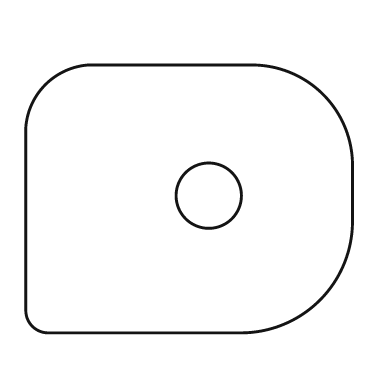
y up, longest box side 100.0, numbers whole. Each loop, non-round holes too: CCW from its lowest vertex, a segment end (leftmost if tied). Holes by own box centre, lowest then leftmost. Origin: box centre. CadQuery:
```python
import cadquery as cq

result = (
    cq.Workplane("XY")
    .moveTo(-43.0, -41.0)
    .lineTo(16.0, -41.0)
    .threePointArc((40.0, -31.0), (50.0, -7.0))
    .lineTo(50.0, 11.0)
    .threePointArc((41.0, 32.0), (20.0, 41.0))
    .lineTo(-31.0, 41.0)
    .threePointArc((-44.0, 35.0), (-50.0, 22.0))
    .lineTo(-50.0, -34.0)
    .threePointArc((-48.0, -39.0), (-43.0, -41.0))
    .close()
    .moveTo(6.0, 1.0)
    .circle(10.0)
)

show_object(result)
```